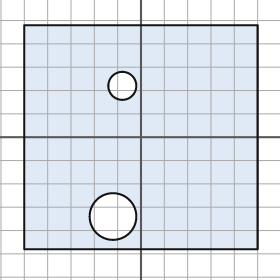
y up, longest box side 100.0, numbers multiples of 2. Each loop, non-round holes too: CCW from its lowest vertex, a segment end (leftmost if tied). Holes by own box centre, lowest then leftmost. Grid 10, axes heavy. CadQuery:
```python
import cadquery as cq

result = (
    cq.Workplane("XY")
    .moveTo(-50.0, -48.0)
    .lineTo(50.0, -48.0)
    .lineTo(50.0, 48.0)
    .lineTo(-50.0, 48.0)
    .close()
    .moveTo(-12.0, -34.0)
    .circle(10.0)
    .moveTo(-8.0, 22.0)
    .circle(6.0)
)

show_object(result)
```